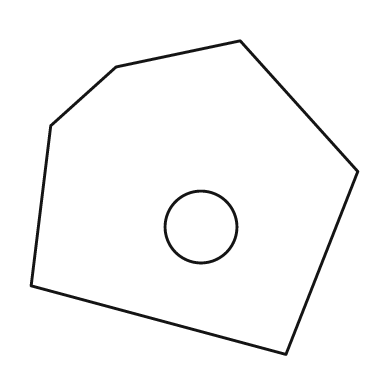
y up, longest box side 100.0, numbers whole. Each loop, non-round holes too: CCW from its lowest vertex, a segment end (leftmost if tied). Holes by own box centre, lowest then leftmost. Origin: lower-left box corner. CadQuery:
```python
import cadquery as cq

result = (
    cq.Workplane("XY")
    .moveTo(78.0, 0.0)
    .lineTo(100.0, 56.0)
    .lineTo(64.0, 96.0)
    .lineTo(26.0, 88.0)
    .lineTo(6.0, 70.0)
    .lineTo(0.0, 21.0)
    .close()
    .moveTo(52.0, 39.0)
    .circle(11.0)
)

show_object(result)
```